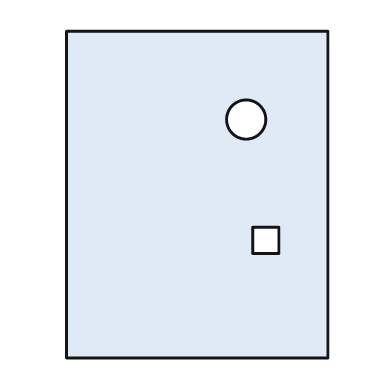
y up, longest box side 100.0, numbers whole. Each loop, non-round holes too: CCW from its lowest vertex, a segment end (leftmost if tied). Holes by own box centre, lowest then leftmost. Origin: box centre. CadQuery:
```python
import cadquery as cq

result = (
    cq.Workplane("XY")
    .moveTo(-40.0, -50.0)
    .lineTo(40.0, -50.0)
    .lineTo(40.0, 50.0)
    .lineTo(-40.0, 50.0)
    .close()
    .moveTo(17.0, -18.0)
    .lineTo(25.0, -18.0)
    .lineTo(25.0, -10.0)
    .lineTo(17.0, -10.0)
    .close()
    .moveTo(15.0, 23.0)
    .circle(6.0)
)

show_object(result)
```